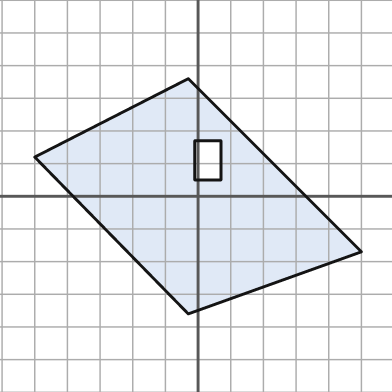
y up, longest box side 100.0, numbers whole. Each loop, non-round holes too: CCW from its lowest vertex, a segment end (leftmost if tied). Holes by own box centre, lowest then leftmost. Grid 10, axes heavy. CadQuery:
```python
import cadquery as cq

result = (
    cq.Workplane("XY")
    .moveTo(-3.0, -36.0)
    .lineTo(50.0, -17.0)
    .lineTo(-3.0, 36.0)
    .lineTo(-50.0, 12.0)
    .close()
    .moveTo(-1.0, 5.0)
    .lineTo(7.0, 5.0)
    .lineTo(7.0, 17.0)
    .lineTo(-1.0, 17.0)
    .close()
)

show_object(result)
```